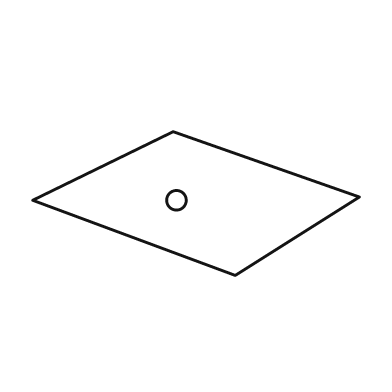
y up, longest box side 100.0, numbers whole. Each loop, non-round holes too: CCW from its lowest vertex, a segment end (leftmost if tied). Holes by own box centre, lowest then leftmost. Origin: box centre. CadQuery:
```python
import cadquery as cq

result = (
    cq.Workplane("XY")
    .moveTo(12.0, -22.0)
    .lineTo(50.0, 2.0)
    .lineTo(-7.0, 22.0)
    .lineTo(-50.0, 1.0)
    .close()
    .moveTo(-6.0, 1.0)
    .circle(3.0)
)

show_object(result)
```